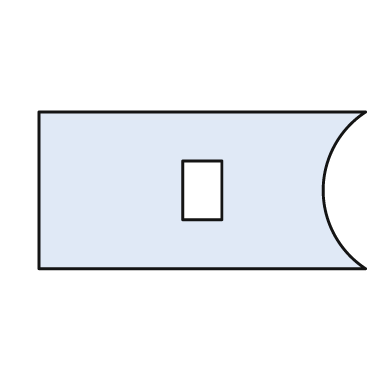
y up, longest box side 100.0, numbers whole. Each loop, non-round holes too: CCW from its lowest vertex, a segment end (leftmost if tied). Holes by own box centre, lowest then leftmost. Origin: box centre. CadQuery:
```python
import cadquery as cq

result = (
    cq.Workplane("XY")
    .moveTo(-50.0, -24.0)
    .lineTo(50.0, -24.0)
    .threePointArc((37.0, 0.0), (50.0, 24.0))
    .lineTo(-50.0, 24.0)
    .close()
    .moveTo(-6.0, -9.0)
    .lineTo(6.0, -9.0)
    .lineTo(6.0, 9.0)
    .lineTo(-6.0, 9.0)
    .close()
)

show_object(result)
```